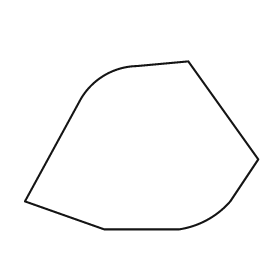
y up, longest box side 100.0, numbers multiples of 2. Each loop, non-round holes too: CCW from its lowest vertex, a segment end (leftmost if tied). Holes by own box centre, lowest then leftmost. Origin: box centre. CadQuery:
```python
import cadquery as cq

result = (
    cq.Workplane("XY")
    .moveTo(-16.0, -36.0)
    .lineTo(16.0, -36.0)
    .threePointArc((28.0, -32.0), (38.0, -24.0))
    .lineTo(50.0, -6.0)
    .lineTo(20.0, 36.0)
    .lineTo(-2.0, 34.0)
    .threePointArc((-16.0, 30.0), (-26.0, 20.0))
    .lineTo(-50.0, -24.0)
    .close()
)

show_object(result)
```